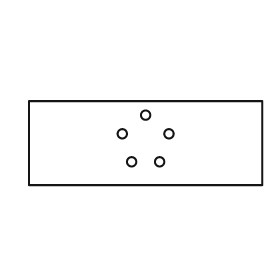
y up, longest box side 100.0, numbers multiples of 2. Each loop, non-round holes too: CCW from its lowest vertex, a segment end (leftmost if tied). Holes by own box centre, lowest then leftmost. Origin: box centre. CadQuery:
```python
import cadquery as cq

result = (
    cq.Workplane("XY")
    .moveTo(-50.0, -18.0)
    .lineTo(50.0, -18.0)
    .lineTo(50.0, 18.0)
    .lineTo(-50.0, 18.0)
    .close()
    .moveTo(-6.0, -8.0)
    .circle(2.0)
    .moveTo(6.0, -8.0)
    .circle(2.0)
    .moveTo(-10.0, 4.0)
    .circle(2.0)
    .moveTo(10.0, 4.0)
    .circle(2.0)
    .moveTo(0.0, 12.0)
    .circle(2.0)
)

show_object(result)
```